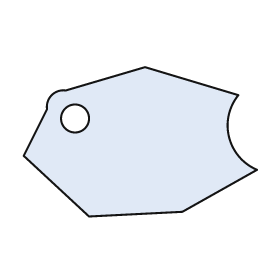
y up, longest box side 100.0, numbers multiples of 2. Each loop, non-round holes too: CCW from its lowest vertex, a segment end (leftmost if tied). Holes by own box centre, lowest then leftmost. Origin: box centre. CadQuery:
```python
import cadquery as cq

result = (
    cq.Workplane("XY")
    .moveTo(-22.0, -32.0)
    .lineTo(18.0, -30.0)
    .lineTo(50.0, -12.0)
    .threePointArc((38.0, 2.0), (42.0, 20.0))
    .lineTo(2.0, 32.0)
    .lineTo(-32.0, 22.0)
    .threePointArc((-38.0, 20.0), (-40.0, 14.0))
    .lineTo(-50.0, -6.0)
    .close()
    .moveTo(-28.0, 10.0)
    .circle(6.0)
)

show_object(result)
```